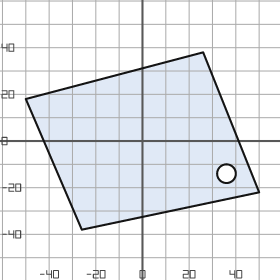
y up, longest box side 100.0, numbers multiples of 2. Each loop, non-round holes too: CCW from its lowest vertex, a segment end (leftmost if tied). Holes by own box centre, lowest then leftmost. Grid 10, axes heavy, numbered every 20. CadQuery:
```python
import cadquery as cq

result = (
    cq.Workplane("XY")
    .moveTo(-26.0, -38.0)
    .lineTo(50.0, -22.0)
    .lineTo(26.0, 38.0)
    .lineTo(-50.0, 18.0)
    .close()
    .moveTo(36.0, -14.0)
    .circle(4.0)
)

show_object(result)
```